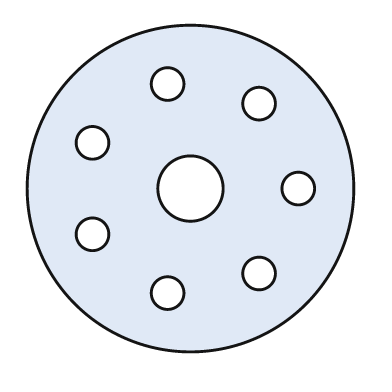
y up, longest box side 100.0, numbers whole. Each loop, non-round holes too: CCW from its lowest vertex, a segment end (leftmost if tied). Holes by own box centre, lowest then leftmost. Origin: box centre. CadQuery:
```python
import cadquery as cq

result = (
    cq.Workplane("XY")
    .moveTo(0.0, 0.0)
    .circle(50.0)
    .moveTo(-7.0, -32.0)
    .circle(5.0)
    .moveTo(21.0, -26.0)
    .circle(5.0)
    .moveTo(-30.0, -14.0)
    .circle(5.0)
    .moveTo(0.0, 0.0)
    .circle(10.0)
    .moveTo(33.0, 0.0)
    .circle(5.0)
    .moveTo(-30.0, 14.0)
    .circle(5.0)
    .moveTo(21.0, 26.0)
    .circle(5.0)
    .moveTo(-7.0, 32.0)
    .circle(5.0)
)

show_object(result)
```